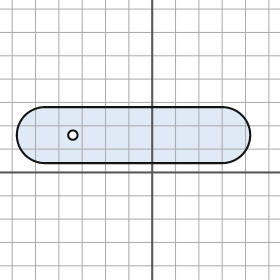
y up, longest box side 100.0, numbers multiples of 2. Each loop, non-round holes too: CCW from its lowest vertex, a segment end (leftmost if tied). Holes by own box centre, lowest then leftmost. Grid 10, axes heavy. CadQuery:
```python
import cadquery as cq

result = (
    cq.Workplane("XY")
    .moveTo(-46.0, 4.0)
    .lineTo(30.0, 4.0)
    .threePointArc((42.0, 16.0), (30.0, 28.0))
    .lineTo(-46.0, 28.0)
    .threePointArc((-58.0, 16.0), (-46.0, 4.0))
    .close()
    .moveTo(-34.0, 16.0)
    .circle(2.0)
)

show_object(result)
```